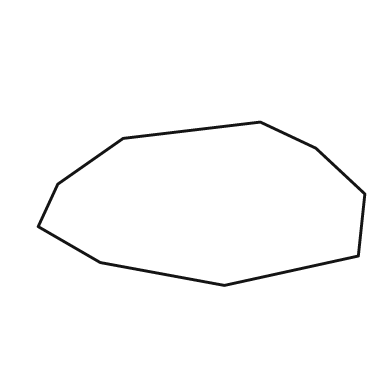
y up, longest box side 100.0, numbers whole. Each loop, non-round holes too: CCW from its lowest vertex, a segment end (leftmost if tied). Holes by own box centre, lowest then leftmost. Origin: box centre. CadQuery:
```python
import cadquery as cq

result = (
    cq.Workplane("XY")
    .moveTo(7.0, -25.0)
    .lineTo(48.0, -16.0)
    .lineTo(50.0, 3.0)
    .lineTo(35.0, 17.0)
    .lineTo(18.0, 25.0)
    .lineTo(-24.0, 20.0)
    .lineTo(-44.0, 6.0)
    .lineTo(-50.0, -7.0)
    .lineTo(-31.0, -18.0)
    .close()
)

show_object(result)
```